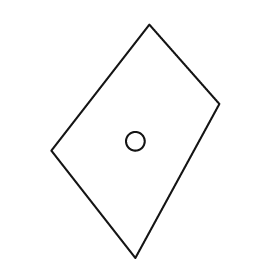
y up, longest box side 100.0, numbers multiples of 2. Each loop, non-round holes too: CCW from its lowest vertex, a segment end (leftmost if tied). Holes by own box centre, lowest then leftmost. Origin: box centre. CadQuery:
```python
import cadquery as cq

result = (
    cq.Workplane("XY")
    .moveTo(0.0, -50.0)
    .lineTo(36.0, 16.0)
    .lineTo(6.0, 50.0)
    .lineTo(-36.0, -4.0)
    .close()
    .moveTo(0.0, 0.0)
    .circle(4.0)
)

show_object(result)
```